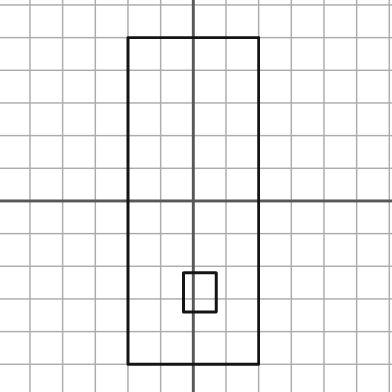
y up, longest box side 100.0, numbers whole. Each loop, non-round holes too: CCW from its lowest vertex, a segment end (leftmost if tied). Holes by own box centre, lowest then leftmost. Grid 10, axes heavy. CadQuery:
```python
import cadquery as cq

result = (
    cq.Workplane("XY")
    .moveTo(-20.0, -50.0)
    .lineTo(20.0, -50.0)
    .lineTo(20.0, 50.0)
    .lineTo(-20.0, 50.0)
    .close()
    .moveTo(-3.0, -34.0)
    .lineTo(7.0, -34.0)
    .lineTo(7.0, -22.0)
    .lineTo(-3.0, -22.0)
    .close()
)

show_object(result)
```